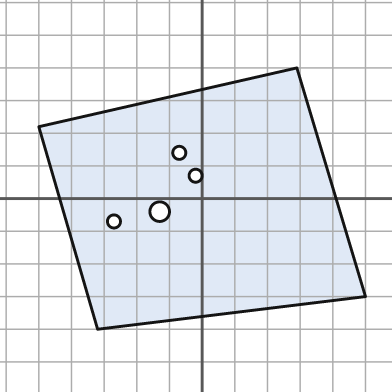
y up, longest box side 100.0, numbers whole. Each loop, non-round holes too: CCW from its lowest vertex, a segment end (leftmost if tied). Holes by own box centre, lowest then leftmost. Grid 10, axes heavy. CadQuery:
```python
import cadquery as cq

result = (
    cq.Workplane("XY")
    .moveTo(-32.0, -40.0)
    .lineTo(50.0, -30.0)
    .lineTo(29.0, 40.0)
    .lineTo(-50.0, 22.0)
    .close()
    .moveTo(-27.0, -7.0)
    .circle(2.0)
    .moveTo(-13.0, -4.0)
    .circle(3.0)
    .moveTo(-2.0, 7.0)
    .circle(2.0)
    .moveTo(-7.0, 14.0)
    .circle(2.0)
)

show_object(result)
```